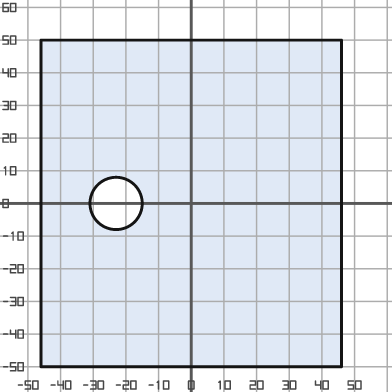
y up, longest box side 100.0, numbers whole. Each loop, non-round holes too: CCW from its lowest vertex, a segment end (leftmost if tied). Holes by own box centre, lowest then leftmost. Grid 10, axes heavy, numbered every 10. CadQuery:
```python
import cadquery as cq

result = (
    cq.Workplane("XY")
    .moveTo(-46.0, -50.0)
    .lineTo(46.0, -50.0)
    .lineTo(46.0, 50.0)
    .lineTo(-46.0, 50.0)
    .close()
    .moveTo(-23.0, 0.0)
    .circle(8.0)
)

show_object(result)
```